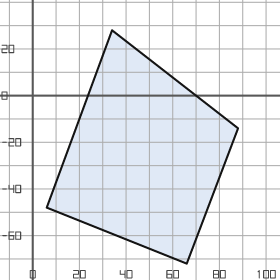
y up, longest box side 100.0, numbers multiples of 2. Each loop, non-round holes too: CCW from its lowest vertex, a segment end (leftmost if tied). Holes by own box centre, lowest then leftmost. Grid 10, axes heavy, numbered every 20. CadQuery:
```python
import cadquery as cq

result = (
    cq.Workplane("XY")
    .moveTo(66.0, -72.0)
    .lineTo(88.0, -14.0)
    .lineTo(34.0, 28.0)
    .lineTo(6.0, -48.0)
    .close()
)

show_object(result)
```